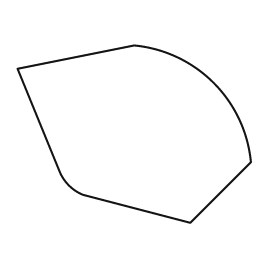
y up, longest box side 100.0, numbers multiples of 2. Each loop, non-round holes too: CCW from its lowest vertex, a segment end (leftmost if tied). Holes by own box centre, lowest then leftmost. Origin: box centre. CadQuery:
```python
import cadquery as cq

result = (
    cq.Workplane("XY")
    .moveTo(24.0, -38.0)
    .lineTo(50.0, -12.0)
    .threePointArc((34.0, 22.0), (0.0, 38.0))
    .lineTo(-50.0, 28.0)
    .lineTo(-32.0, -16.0)
    .threePointArc((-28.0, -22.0), (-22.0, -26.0))
    .close()
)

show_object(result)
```